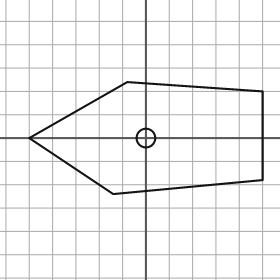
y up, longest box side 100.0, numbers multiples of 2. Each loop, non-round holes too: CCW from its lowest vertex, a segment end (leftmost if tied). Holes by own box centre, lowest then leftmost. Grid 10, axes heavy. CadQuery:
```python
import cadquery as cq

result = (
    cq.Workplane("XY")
    .moveTo(-14.0, -24.0)
    .lineTo(50.0, -18.0)
    .lineTo(50.0, 20.0)
    .lineTo(-8.0, 24.0)
    .lineTo(-50.0, 0.0)
    .close()
    .moveTo(0.0, 0.0)
    .circle(4.0)
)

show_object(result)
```